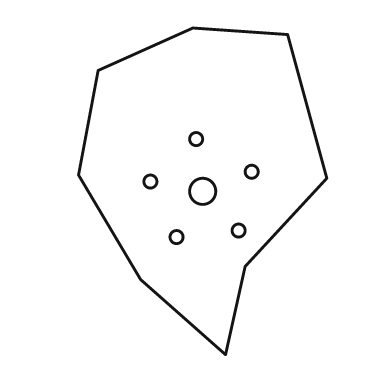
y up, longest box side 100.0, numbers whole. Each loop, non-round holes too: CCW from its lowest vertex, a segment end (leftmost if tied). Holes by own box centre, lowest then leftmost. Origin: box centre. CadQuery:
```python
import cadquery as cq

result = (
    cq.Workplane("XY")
    .moveTo(7.0, -50.0)
    .lineTo(13.0, -23.0)
    .lineTo(38.0, 4.0)
    .lineTo(26.0, 48.0)
    .lineTo(-3.0, 50.0)
    .lineTo(-32.0, 37.0)
    .lineTo(-38.0, 5.0)
    .lineTo(-19.0, -27.0)
    .close()
    .moveTo(-8.0, -14.0)
    .circle(2.0)
    .moveTo(11.0, -12.0)
    .circle(2.0)
    .moveTo(0.0, 0.0)
    .circle(4.0)
    .moveTo(-16.0, 3.0)
    .circle(2.0)
    .moveTo(15.0, 6.0)
    .circle(2.0)
    .moveTo(-2.0, 16.0)
    .circle(2.0)
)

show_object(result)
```